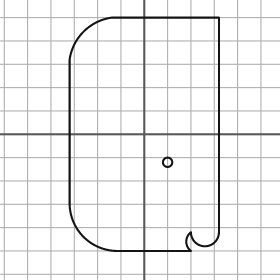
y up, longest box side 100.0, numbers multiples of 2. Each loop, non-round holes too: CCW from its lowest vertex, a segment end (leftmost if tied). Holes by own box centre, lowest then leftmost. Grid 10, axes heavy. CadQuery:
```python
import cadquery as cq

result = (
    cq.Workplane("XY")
    .moveTo(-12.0, -50.0)
    .lineTo(20.0, -50.0)
    .threePointArc((18.0, -46.0), (20.0, -42.0))
    .threePointArc((26.0, -48.0), (32.0, -42.0))
    .lineTo(32.0, 50.0)
    .lineTo(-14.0, 50.0)
    .threePointArc((-26.0, 44.0), (-32.0, 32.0))
    .lineTo(-32.0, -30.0)
    .threePointArc((-26.0, -44.0), (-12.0, -50.0))
    .close()
    .moveTo(10.0, -12.0)
    .circle(2.0)
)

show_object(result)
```